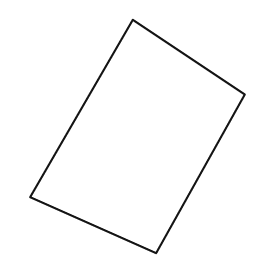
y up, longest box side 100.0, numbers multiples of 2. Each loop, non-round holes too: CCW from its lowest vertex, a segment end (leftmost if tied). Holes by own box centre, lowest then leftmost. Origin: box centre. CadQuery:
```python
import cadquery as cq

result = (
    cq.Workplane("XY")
    .moveTo(8.0, -50.0)
    .lineTo(46.0, 18.0)
    .lineTo(-2.0, 50.0)
    .lineTo(-46.0, -26.0)
    .close()
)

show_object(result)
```